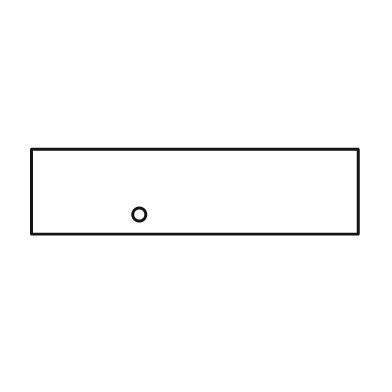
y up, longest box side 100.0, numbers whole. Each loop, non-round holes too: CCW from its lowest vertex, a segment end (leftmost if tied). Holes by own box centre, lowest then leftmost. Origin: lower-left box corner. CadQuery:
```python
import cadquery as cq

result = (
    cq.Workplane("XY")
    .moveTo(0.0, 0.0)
    .lineTo(100.0, 0.0)
    .lineTo(100.0, 26.0)
    .lineTo(0.0, 26.0)
    .close()
    .moveTo(33.0, 6.0)
    .circle(2.0)
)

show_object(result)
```